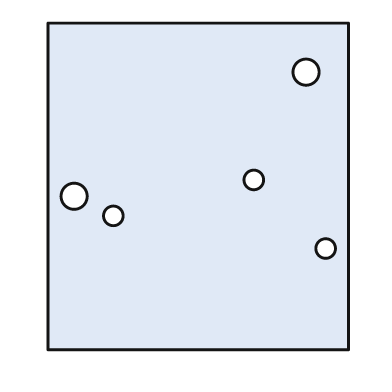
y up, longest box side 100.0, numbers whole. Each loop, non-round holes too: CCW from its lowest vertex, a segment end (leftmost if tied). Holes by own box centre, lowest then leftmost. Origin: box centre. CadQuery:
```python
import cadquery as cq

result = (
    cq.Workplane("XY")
    .moveTo(-46.0, -50.0)
    .lineTo(46.0, -50.0)
    .lineTo(46.0, 50.0)
    .lineTo(-46.0, 50.0)
    .close()
    .moveTo(39.0, -19.0)
    .circle(3.0)
    .moveTo(-26.0, -9.0)
    .circle(3.0)
    .moveTo(-38.0, -3.0)
    .circle(4.0)
    .moveTo(17.0, 2.0)
    .circle(3.0)
    .moveTo(33.0, 35.0)
    .circle(4.0)
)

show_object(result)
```